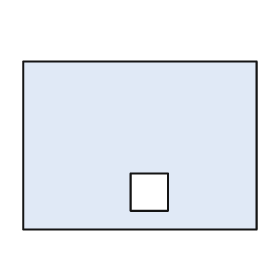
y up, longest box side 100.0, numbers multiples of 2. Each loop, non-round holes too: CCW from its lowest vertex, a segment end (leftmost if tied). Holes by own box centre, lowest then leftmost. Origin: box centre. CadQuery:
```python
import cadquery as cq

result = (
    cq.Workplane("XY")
    .moveTo(-50.0, -36.0)
    .lineTo(50.0, -36.0)
    .lineTo(50.0, 36.0)
    .lineTo(-50.0, 36.0)
    .close()
    .moveTo(-4.0, -28.0)
    .lineTo(12.0, -28.0)
    .lineTo(12.0, -12.0)
    .lineTo(-4.0, -12.0)
    .close()
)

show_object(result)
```